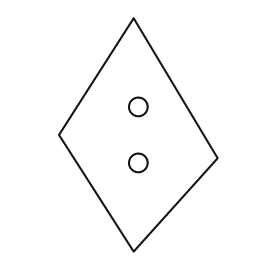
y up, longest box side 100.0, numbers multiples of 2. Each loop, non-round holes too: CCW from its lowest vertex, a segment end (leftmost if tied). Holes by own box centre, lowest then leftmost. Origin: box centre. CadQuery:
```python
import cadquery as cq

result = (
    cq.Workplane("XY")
    .moveTo(-2.0, -50.0)
    .lineTo(34.0, -10.0)
    .lineTo(-2.0, 50.0)
    .lineTo(-34.0, 0.0)
    .close()
    .moveTo(0.0, -12.0)
    .circle(4.0)
    .moveTo(0.0, 12.0)
    .circle(4.0)
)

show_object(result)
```